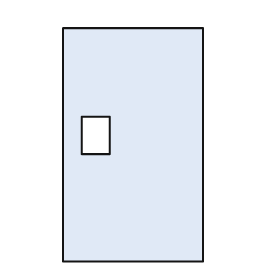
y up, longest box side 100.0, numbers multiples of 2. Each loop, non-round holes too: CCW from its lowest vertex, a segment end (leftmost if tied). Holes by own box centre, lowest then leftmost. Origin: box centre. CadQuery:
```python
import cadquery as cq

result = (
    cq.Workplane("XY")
    .moveTo(-30.0, -50.0)
    .lineTo(30.0, -50.0)
    .lineTo(30.0, 50.0)
    .lineTo(-30.0, 50.0)
    .close()
    .moveTo(-22.0, -4.0)
    .lineTo(-10.0, -4.0)
    .lineTo(-10.0, 12.0)
    .lineTo(-22.0, 12.0)
    .close()
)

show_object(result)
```